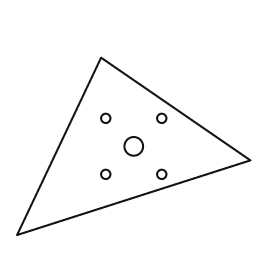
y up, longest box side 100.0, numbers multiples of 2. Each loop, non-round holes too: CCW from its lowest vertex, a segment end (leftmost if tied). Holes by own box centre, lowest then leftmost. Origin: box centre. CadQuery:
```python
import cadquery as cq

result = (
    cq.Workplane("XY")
    .moveTo(-50.0, -38.0)
    .lineTo(50.0, -6.0)
    .lineTo(-14.0, 38.0)
    .close()
    .moveTo(-12.0, -12.0)
    .circle(2.0)
    .moveTo(12.0, -12.0)
    .circle(2.0)
    .moveTo(0.0, 0.0)
    .circle(4.0)
    .moveTo(-12.0, 12.0)
    .circle(2.0)
    .moveTo(12.0, 12.0)
    .circle(2.0)
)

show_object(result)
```